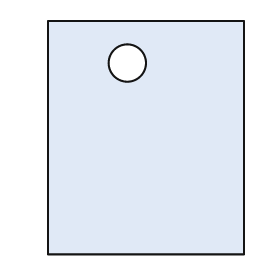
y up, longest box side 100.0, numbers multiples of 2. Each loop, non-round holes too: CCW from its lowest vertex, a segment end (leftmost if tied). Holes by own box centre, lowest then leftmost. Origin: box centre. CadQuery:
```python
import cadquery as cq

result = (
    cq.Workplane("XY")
    .moveTo(-42.0, -50.0)
    .lineTo(42.0, -50.0)
    .lineTo(42.0, 50.0)
    .lineTo(-42.0, 50.0)
    .close()
    .moveTo(-8.0, 32.0)
    .circle(8.0)
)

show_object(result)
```